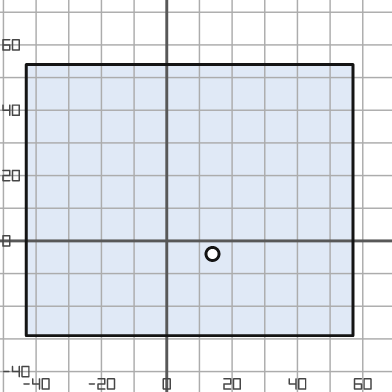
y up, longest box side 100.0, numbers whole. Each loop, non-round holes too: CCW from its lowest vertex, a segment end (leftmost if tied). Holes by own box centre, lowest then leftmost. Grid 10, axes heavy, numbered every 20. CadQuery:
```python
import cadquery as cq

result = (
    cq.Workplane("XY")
    .moveTo(-43.0, -29.0)
    .lineTo(57.0, -29.0)
    .lineTo(57.0, 54.0)
    .lineTo(-43.0, 54.0)
    .close()
    .moveTo(14.0, -4.0)
    .circle(2.0)
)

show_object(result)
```